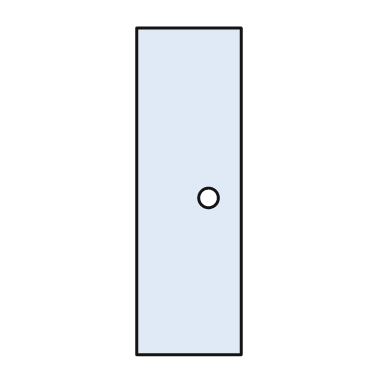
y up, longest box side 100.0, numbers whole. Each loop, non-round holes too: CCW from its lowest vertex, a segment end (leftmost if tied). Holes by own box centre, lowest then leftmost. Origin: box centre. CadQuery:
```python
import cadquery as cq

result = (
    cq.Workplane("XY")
    .moveTo(-16.0, -50.0)
    .lineTo(16.0, -50.0)
    .lineTo(16.0, 50.0)
    .lineTo(-16.0, 50.0)
    .close()
    .moveTo(6.0, -2.0)
    .circle(3.0)
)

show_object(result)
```